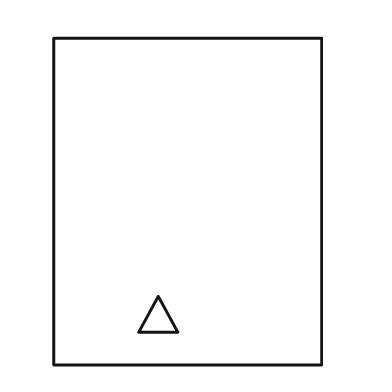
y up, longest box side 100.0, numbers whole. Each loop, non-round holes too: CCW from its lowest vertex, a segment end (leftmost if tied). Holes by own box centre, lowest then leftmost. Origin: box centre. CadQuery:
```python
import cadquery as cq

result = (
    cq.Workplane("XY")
    .moveTo(-41.0, -50.0)
    .lineTo(41.0, -50.0)
    .lineTo(41.0, 50.0)
    .lineTo(-41.0, 50.0)
    .close()
    .moveTo(-15.0, -40.0)
    .lineTo(-3.0, -40.0)
    .lineTo(-9.0, -29.0)
    .close()
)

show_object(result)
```